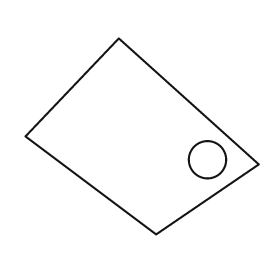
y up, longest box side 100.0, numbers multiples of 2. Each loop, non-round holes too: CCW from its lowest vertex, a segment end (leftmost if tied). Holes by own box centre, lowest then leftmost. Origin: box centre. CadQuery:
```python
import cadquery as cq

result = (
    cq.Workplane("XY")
    .moveTo(6.0, -42.0)
    .lineTo(50.0, -12.0)
    .lineTo(-10.0, 42.0)
    .lineTo(-50.0, 0.0)
    .close()
    .moveTo(28.0, -10.0)
    .circle(8.0)
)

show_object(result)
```